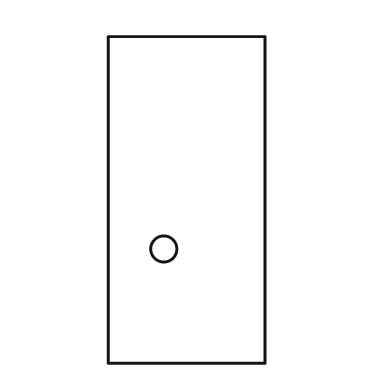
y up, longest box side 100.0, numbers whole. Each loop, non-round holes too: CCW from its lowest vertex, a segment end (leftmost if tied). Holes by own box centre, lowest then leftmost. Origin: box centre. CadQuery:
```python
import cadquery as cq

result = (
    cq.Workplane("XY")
    .moveTo(-24.0, -50.0)
    .lineTo(24.0, -50.0)
    .lineTo(24.0, 50.0)
    .lineTo(-24.0, 50.0)
    .close()
    .moveTo(-7.0, -15.0)
    .circle(4.0)
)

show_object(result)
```